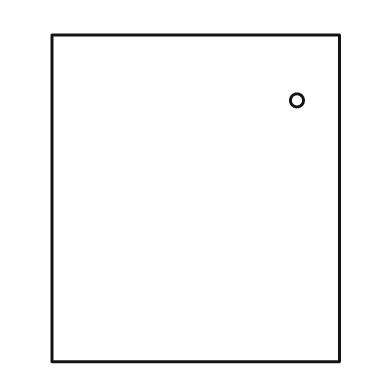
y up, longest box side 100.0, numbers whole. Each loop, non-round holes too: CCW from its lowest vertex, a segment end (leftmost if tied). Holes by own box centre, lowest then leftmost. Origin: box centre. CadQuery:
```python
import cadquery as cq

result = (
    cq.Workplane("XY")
    .moveTo(-44.0, -50.0)
    .lineTo(44.0, -50.0)
    .lineTo(44.0, 50.0)
    .lineTo(-44.0, 50.0)
    .close()
    .moveTo(31.0, 30.0)
    .circle(2.0)
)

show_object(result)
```